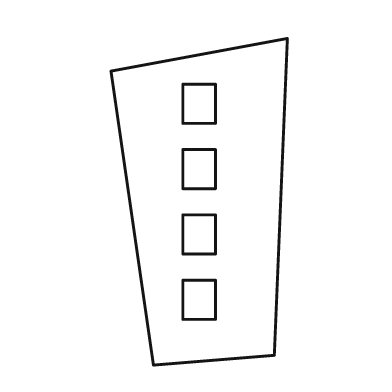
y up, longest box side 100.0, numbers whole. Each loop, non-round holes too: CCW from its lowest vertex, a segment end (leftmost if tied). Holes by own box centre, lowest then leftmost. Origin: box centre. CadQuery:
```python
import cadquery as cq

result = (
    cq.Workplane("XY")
    .moveTo(-14.0, -50.0)
    .lineTo(23.0, -47.0)
    .lineTo(27.0, 50.0)
    .lineTo(-27.0, 40.0)
    .close()
    .moveTo(-5.0, -36.0)
    .lineTo(5.0, -36.0)
    .lineTo(5.0, -24.0)
    .lineTo(-5.0, -24.0)
    .close()
    .moveTo(-5.0, -16.0)
    .lineTo(5.0, -16.0)
    .lineTo(5.0, -4.0)
    .lineTo(-5.0, -4.0)
    .close()
    .moveTo(-5.0, 4.0)
    .lineTo(5.0, 4.0)
    .lineTo(5.0, 16.0)
    .lineTo(-5.0, 16.0)
    .close()
    .moveTo(-5.0, 24.0)
    .lineTo(5.0, 24.0)
    .lineTo(5.0, 36.0)
    .lineTo(-5.0, 36.0)
    .close()
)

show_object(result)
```